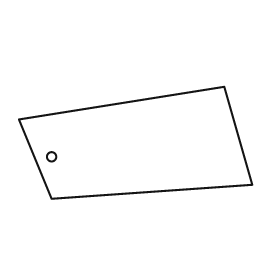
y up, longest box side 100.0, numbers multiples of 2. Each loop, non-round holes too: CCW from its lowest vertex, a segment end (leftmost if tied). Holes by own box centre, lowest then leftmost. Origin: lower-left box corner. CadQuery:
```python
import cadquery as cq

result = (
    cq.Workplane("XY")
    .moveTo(14.0, 0.0)
    .lineTo(100.0, 6.0)
    .lineTo(88.0, 48.0)
    .lineTo(0.0, 34.0)
    .close()
    .moveTo(14.0, 18.0)
    .circle(2.0)
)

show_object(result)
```